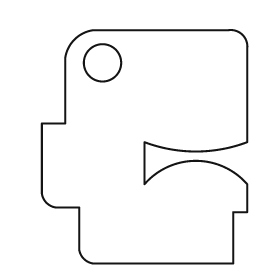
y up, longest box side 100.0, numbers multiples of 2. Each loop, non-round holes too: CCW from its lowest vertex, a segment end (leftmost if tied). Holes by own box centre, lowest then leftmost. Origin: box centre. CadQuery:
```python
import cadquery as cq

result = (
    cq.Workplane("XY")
    .moveTo(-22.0, -50.0)
    .lineTo(38.0, -50.0)
    .lineTo(38.0, -28.0)
    .lineTo(44.0, -28.0)
    .lineTo(44.0, -16.0)
    .threePointArc((22.0, -6.0), (0.0, -16.0))
    .lineTo(0.0, 2.0)
    .threePointArc((22.0, -2.0), (44.0, 2.0))
    .lineTo(44.0, 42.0)
    .threePointArc((42.0, 48.0), (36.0, 50.0))
    .lineTo(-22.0, 50.0)
    .threePointArc((-30.0, 46.0), (-34.0, 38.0))
    .lineTo(-34.0, 10.0)
    .lineTo(-44.0, 10.0)
    .lineTo(-44.0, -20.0)
    .threePointArc((-42.0, -24.0), (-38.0, -26.0))
    .lineTo(-28.0, -26.0)
    .lineTo(-28.0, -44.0)
    .threePointArc((-26.0, -48.0), (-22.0, -50.0))
    .close()
    .moveTo(-18.0, 36.0)
    .circle(8.0)
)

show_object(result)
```